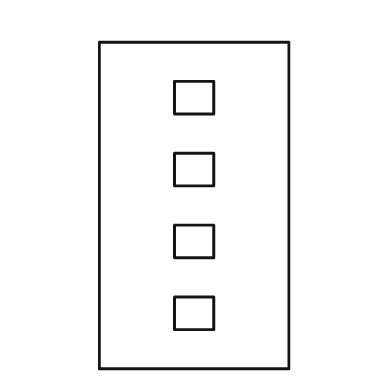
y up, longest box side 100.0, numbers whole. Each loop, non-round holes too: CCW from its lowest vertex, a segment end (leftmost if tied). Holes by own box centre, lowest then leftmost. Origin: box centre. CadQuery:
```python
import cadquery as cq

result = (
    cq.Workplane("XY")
    .moveTo(-29.0, -50.0)
    .lineTo(29.0, -50.0)
    .lineTo(29.0, 50.0)
    .lineTo(-29.0, 50.0)
    .close()
    .moveTo(-6.0, -38.0)
    .lineTo(6.0, -38.0)
    .lineTo(6.0, -28.0)
    .lineTo(-6.0, -28.0)
    .close()
    .moveTo(-6.0, -16.0)
    .lineTo(6.0, -16.0)
    .lineTo(6.0, -6.0)
    .lineTo(-6.0, -6.0)
    .close()
    .moveTo(-6.0, 6.0)
    .lineTo(6.0, 6.0)
    .lineTo(6.0, 16.0)
    .lineTo(-6.0, 16.0)
    .close()
    .moveTo(-6.0, 28.0)
    .lineTo(6.0, 28.0)
    .lineTo(6.0, 38.0)
    .lineTo(-6.0, 38.0)
    .close()
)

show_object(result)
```